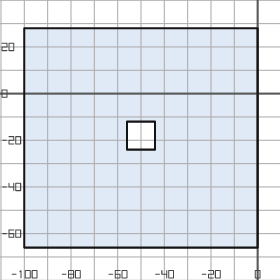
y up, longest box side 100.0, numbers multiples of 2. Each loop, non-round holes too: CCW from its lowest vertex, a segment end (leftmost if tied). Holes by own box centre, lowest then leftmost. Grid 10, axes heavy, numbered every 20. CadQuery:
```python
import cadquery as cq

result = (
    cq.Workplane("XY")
    .moveTo(-100.0, -66.0)
    .lineTo(0.0, -66.0)
    .lineTo(0.0, 28.0)
    .lineTo(-100.0, 28.0)
    .close()
    .moveTo(-56.0, -24.0)
    .lineTo(-44.0, -24.0)
    .lineTo(-44.0, -12.0)
    .lineTo(-56.0, -12.0)
    .close()
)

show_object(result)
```